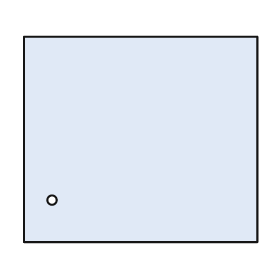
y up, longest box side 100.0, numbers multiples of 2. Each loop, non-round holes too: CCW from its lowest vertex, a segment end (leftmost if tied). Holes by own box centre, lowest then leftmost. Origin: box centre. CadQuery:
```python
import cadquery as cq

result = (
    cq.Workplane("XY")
    .moveTo(-50.0, -44.0)
    .lineTo(50.0, -44.0)
    .lineTo(50.0, 44.0)
    .lineTo(-50.0, 44.0)
    .close()
    .moveTo(-38.0, -26.0)
    .circle(2.0)
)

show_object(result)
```